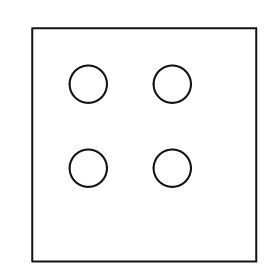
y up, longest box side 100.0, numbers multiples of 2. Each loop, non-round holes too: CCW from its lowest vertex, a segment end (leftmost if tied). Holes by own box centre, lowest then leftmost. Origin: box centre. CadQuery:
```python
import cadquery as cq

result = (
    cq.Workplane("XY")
    .moveTo(-48.0, -50.0)
    .lineTo(48.0, -50.0)
    .lineTo(48.0, 50.0)
    .lineTo(-48.0, 50.0)
    .close()
    .moveTo(-24.0, -10.0)
    .circle(8.0)
    .moveTo(12.0, -10.0)
    .circle(8.0)
    .moveTo(-24.0, 26.0)
    .circle(8.0)
    .moveTo(12.0, 26.0)
    .circle(8.0)
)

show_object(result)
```